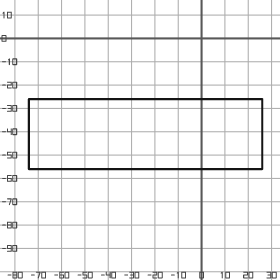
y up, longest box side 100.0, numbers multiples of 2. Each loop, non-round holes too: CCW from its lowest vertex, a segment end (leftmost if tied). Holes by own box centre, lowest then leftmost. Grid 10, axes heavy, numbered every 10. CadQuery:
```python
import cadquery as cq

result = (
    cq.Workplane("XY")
    .moveTo(-74.0, -56.0)
    .lineTo(26.0, -56.0)
    .lineTo(26.0, -26.0)
    .lineTo(-74.0, -26.0)
    .close()
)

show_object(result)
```